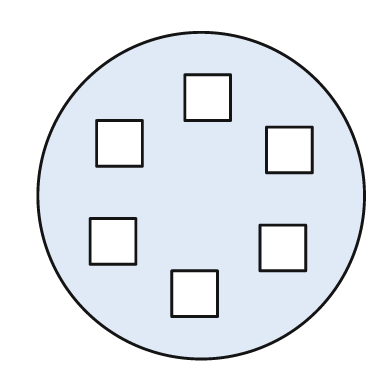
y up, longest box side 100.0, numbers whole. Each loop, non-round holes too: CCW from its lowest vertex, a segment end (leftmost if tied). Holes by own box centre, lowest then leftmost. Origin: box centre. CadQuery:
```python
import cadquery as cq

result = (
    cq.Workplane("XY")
    .moveTo(0.0, 0.0)
    .circle(50.0)
    .moveTo(-9.0, -37.0)
    .lineTo(5.0, -37.0)
    .lineTo(5.0, -23.0)
    .lineTo(-9.0, -23.0)
    .close()
    .moveTo(18.0, -23.0)
    .lineTo(32.0, -23.0)
    .lineTo(32.0, -9.0)
    .lineTo(18.0, -9.0)
    .close()
    .moveTo(-34.0, -21.0)
    .lineTo(-20.0, -21.0)
    .lineTo(-20.0, -7.0)
    .lineTo(-34.0, -7.0)
    .close()
    .moveTo(20.0, 7.0)
    .lineTo(34.0, 7.0)
    .lineTo(34.0, 21.0)
    .lineTo(20.0, 21.0)
    .close()
    .moveTo(-32.0, 9.0)
    .lineTo(-18.0, 9.0)
    .lineTo(-18.0, 23.0)
    .lineTo(-32.0, 23.0)
    .close()
    .moveTo(-5.0, 23.0)
    .lineTo(9.0, 23.0)
    .lineTo(9.0, 37.0)
    .lineTo(-5.0, 37.0)
    .close()
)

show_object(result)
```